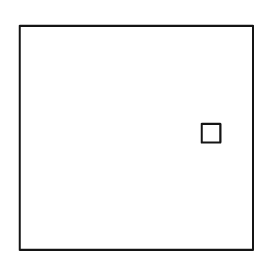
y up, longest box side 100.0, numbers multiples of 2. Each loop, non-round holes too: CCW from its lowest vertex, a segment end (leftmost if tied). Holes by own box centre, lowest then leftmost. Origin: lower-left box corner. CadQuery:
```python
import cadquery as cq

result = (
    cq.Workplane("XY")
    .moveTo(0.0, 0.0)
    .lineTo(100.0, 0.0)
    .lineTo(100.0, 96.0)
    .lineTo(0.0, 96.0)
    .close()
    .moveTo(78.0, 46.0)
    .lineTo(86.0, 46.0)
    .lineTo(86.0, 54.0)
    .lineTo(78.0, 54.0)
    .close()
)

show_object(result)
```